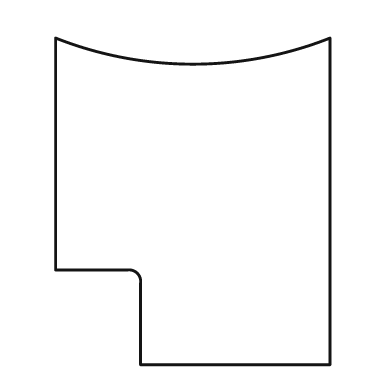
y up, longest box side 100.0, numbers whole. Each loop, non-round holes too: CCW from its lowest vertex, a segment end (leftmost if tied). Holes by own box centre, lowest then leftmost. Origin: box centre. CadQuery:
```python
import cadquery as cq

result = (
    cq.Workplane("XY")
    .moveTo(-16.0, -50.0)
    .lineTo(42.0, -50.0)
    .lineTo(42.0, 50.0)
    .threePointArc((0.0, 42.0), (-42.0, 50.0))
    .lineTo(-42.0, -21.0)
    .lineTo(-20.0, -21.0)
    .threePointArc((-17.0, -22.0), (-16.0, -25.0))
    .close()
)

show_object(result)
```